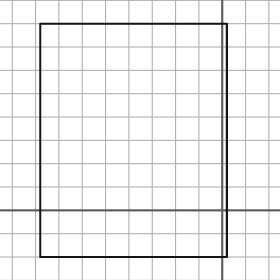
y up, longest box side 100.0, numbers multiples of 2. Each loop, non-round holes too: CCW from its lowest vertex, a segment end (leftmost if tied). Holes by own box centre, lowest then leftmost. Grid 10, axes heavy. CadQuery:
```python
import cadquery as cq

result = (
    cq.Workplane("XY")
    .moveTo(-78.0, -20.0)
    .lineTo(2.0, -20.0)
    .lineTo(2.0, 80.0)
    .lineTo(-78.0, 80.0)
    .close()
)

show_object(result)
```